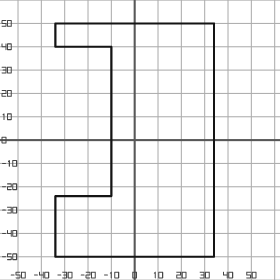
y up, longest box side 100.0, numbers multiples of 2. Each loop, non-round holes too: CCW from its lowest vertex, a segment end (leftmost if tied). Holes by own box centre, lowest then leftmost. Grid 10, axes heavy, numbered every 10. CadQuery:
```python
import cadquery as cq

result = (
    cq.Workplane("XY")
    .moveTo(-34.0, -50.0)
    .lineTo(34.0, -50.0)
    .lineTo(34.0, 50.0)
    .lineTo(-34.0, 50.0)
    .lineTo(-34.0, 40.0)
    .lineTo(-10.0, 40.0)
    .lineTo(-10.0, -24.0)
    .lineTo(-34.0, -24.0)
    .close()
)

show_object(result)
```